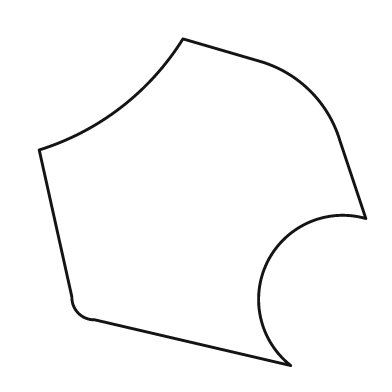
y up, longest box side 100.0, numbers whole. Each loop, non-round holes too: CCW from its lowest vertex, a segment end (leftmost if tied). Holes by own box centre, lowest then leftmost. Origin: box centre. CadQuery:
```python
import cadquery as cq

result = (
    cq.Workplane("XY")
    .moveTo(27.0, -50.0)
    .threePointArc((20.0, -18.0), (50.0, -5.0))
    .lineTo(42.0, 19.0)
    .threePointArc((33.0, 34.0), (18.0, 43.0))
    .lineTo(-6.0, 50.0)
    .threePointArc((-25.0, 29.0), (-50.0, 16.0))
    .lineTo(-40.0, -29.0)
    .threePointArc((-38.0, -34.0), (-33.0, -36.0))
    .close()
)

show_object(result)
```